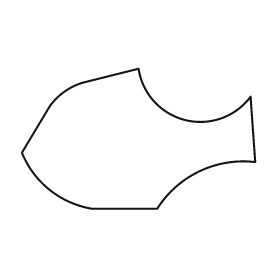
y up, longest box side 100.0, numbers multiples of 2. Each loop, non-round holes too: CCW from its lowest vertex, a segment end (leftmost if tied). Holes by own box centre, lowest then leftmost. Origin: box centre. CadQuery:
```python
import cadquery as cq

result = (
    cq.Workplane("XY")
    .moveTo(-20.0, -30.0)
    .lineTo(8.0, -30.0)
    .threePointArc((26.0, -14.0), (50.0, -10.0))
    .lineTo(48.0, 18.0)
    .threePointArc((20.0, 8.0), (0.0, 30.0))
    .lineTo(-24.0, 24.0)
    .threePointArc((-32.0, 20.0), (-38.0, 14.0))
    .lineTo(-50.0, -6.0)
    .threePointArc((-38.0, -22.0), (-20.0, -30.0))
    .close()
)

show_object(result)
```